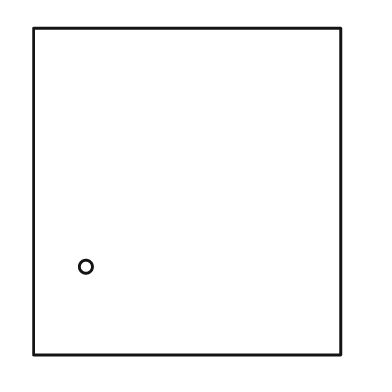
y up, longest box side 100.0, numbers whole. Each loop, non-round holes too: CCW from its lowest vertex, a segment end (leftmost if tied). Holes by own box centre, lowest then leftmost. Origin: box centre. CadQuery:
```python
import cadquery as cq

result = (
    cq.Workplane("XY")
    .moveTo(-47.0, -50.0)
    .lineTo(47.0, -50.0)
    .lineTo(47.0, 50.0)
    .lineTo(-47.0, 50.0)
    .close()
    .moveTo(-31.0, -23.0)
    .circle(2.0)
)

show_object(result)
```